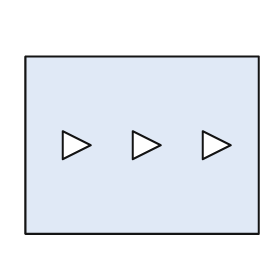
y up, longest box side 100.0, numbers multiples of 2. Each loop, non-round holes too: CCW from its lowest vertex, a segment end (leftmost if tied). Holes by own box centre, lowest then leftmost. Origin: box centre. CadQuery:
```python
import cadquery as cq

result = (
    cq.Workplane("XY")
    .moveTo(-50.0, -38.0)
    .lineTo(50.0, -38.0)
    .lineTo(50.0, 38.0)
    .lineTo(-50.0, 38.0)
    .close()
    .moveTo(-34.0, -6.0)
    .lineTo(-22.0, 0.0)
    .lineTo(-34.0, 6.0)
    .close()
    .moveTo(-4.0, -6.0)
    .lineTo(8.0, 0.0)
    .lineTo(-4.0, 6.0)
    .close()
    .moveTo(26.0, -6.0)
    .lineTo(38.0, 0.0)
    .lineTo(26.0, 6.0)
    .close()
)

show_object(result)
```